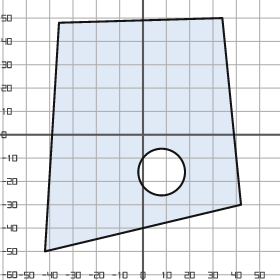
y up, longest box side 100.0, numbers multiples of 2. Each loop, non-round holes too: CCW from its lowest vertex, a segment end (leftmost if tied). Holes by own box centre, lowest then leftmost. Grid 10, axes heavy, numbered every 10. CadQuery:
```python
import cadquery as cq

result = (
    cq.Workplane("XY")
    .moveTo(-42.0, -50.0)
    .lineTo(42.0, -30.0)
    .lineTo(34.0, 50.0)
    .lineTo(-36.0, 48.0)
    .close()
    .moveTo(8.0, -16.0)
    .circle(10.0)
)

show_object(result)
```